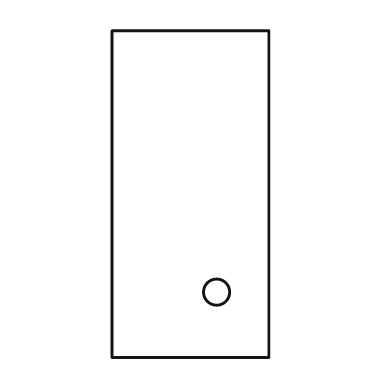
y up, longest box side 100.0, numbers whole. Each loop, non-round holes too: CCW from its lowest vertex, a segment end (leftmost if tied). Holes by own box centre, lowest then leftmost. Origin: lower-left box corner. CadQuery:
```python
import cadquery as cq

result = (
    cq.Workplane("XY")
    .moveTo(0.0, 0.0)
    .lineTo(48.0, 0.0)
    .lineTo(48.0, 100.0)
    .lineTo(0.0, 100.0)
    .close()
    .moveTo(32.0, 20.0)
    .circle(4.0)
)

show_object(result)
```